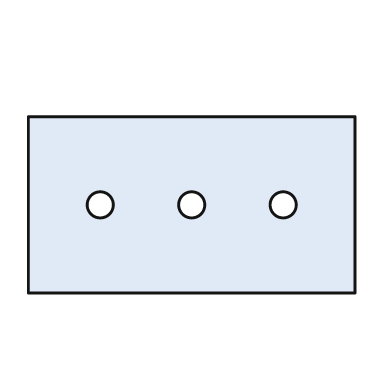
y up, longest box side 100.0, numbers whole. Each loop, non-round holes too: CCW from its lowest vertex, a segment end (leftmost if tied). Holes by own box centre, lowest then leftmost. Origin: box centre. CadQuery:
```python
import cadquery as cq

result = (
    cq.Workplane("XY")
    .moveTo(-50.0, -27.0)
    .lineTo(50.0, -27.0)
    .lineTo(50.0, 27.0)
    .lineTo(-50.0, 27.0)
    .close()
    .moveTo(-28.0, 0.0)
    .circle(4.0)
    .moveTo(0.0, 0.0)
    .circle(4.0)
    .moveTo(28.0, 0.0)
    .circle(4.0)
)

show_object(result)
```